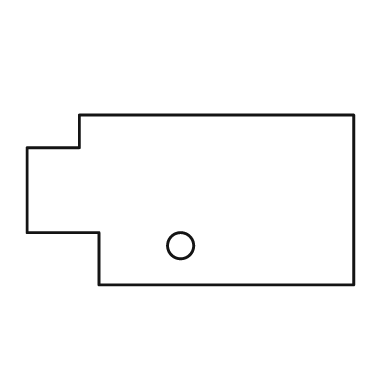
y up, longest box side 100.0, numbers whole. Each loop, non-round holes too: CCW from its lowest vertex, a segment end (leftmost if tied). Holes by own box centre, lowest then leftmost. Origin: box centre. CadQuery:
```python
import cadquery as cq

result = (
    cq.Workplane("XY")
    .moveTo(-28.0, -26.0)
    .lineTo(50.0, -26.0)
    .lineTo(50.0, 26.0)
    .lineTo(-34.0, 26.0)
    .lineTo(-34.0, 16.0)
    .lineTo(-50.0, 16.0)
    .lineTo(-50.0, -10.0)
    .lineTo(-28.0, -10.0)
    .close()
    .moveTo(-3.0, -14.0)
    .circle(4.0)
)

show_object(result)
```